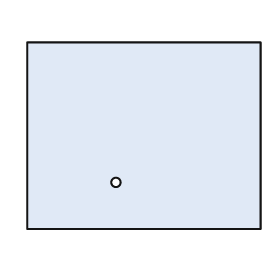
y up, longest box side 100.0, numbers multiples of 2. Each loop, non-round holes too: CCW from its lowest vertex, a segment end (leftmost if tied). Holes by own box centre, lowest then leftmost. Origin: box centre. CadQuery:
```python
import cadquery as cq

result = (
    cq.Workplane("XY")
    .moveTo(-50.0, -40.0)
    .lineTo(50.0, -40.0)
    .lineTo(50.0, 40.0)
    .lineTo(-50.0, 40.0)
    .close()
    .moveTo(-12.0, -20.0)
    .circle(2.0)
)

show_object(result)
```